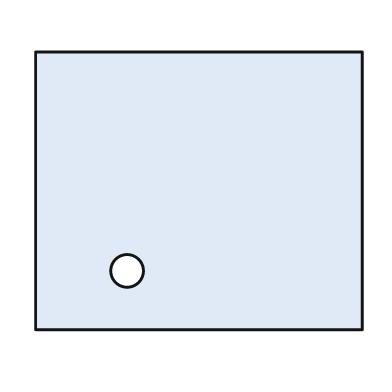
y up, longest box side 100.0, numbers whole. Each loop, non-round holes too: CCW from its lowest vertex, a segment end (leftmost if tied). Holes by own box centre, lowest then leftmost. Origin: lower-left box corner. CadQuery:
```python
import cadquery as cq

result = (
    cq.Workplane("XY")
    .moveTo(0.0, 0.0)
    .lineTo(100.0, 0.0)
    .lineTo(100.0, 85.0)
    .lineTo(0.0, 85.0)
    .close()
    .moveTo(28.0, 18.0)
    .circle(5.0)
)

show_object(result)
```